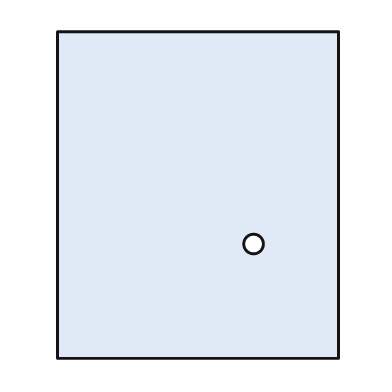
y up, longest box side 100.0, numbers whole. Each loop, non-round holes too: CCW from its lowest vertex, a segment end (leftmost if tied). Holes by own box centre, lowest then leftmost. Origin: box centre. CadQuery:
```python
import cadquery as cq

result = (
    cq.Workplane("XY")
    .moveTo(-43.0, -50.0)
    .lineTo(43.0, -50.0)
    .lineTo(43.0, 50.0)
    .lineTo(-43.0, 50.0)
    .close()
    .moveTo(17.0, -15.0)
    .circle(3.0)
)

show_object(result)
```